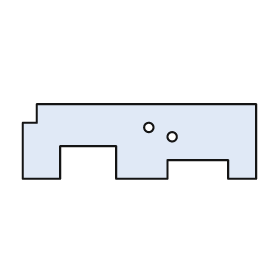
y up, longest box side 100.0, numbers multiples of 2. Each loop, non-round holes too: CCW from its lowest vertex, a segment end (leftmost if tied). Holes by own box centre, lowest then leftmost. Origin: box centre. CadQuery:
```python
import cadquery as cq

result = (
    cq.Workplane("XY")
    .moveTo(-50.0, -16.0)
    .lineTo(-34.0, -16.0)
    .lineTo(-34.0, -2.0)
    .lineTo(-10.0, -2.0)
    .lineTo(-10.0, -16.0)
    .lineTo(12.0, -16.0)
    .lineTo(12.0, -8.0)
    .lineTo(38.0, -8.0)
    .lineTo(38.0, -16.0)
    .lineTo(50.0, -16.0)
    .lineTo(50.0, 16.0)
    .lineTo(-44.0, 16.0)
    .lineTo(-44.0, 8.0)
    .lineTo(-50.0, 8.0)
    .close()
    .moveTo(14.0, 2.0)
    .circle(2.0)
    .moveTo(4.0, 6.0)
    .circle(2.0)
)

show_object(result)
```